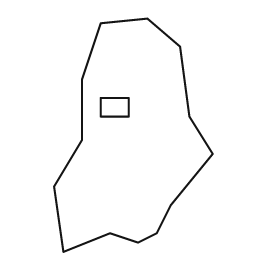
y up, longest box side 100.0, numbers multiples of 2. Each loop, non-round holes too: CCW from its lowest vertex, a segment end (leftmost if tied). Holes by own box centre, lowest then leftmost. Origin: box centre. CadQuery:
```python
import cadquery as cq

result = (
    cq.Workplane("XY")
    .moveTo(-30.0, -50.0)
    .lineTo(-10.0, -42.0)
    .lineTo(2.0, -46.0)
    .lineTo(10.0, -42.0)
    .lineTo(16.0, -30.0)
    .lineTo(34.0, -8.0)
    .lineTo(24.0, 8.0)
    .lineTo(20.0, 38.0)
    .lineTo(6.0, 50.0)
    .lineTo(-14.0, 48.0)
    .lineTo(-22.0, 24.0)
    .lineTo(-22.0, -2.0)
    .lineTo(-34.0, -22.0)
    .close()
    .moveTo(-14.0, 8.0)
    .lineTo(-2.0, 8.0)
    .lineTo(-2.0, 16.0)
    .lineTo(-14.0, 16.0)
    .close()
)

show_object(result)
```